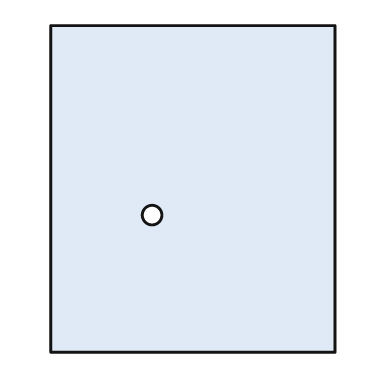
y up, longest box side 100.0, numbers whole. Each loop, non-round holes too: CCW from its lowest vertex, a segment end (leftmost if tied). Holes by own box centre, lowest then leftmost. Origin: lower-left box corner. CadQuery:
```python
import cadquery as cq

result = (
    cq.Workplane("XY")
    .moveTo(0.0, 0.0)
    .lineTo(87.0, 0.0)
    .lineTo(87.0, 100.0)
    .lineTo(0.0, 100.0)
    .close()
    .moveTo(31.0, 42.0)
    .circle(3.0)
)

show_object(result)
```